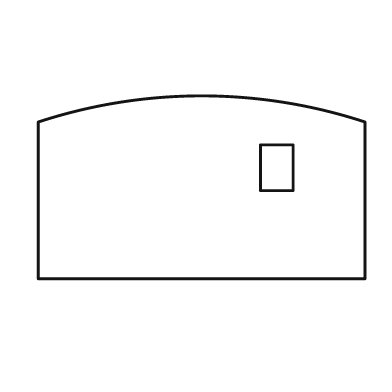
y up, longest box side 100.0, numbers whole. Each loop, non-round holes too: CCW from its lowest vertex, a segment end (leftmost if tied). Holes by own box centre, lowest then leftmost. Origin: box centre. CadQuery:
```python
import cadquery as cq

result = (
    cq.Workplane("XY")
    .moveTo(-50.0, -28.0)
    .lineTo(50.0, -28.0)
    .lineTo(50.0, 20.0)
    .threePointArc((0.0, 28.0), (-50.0, 20.0))
    .close()
    .moveTo(18.0, -1.0)
    .lineTo(28.0, -1.0)
    .lineTo(28.0, 13.0)
    .lineTo(18.0, 13.0)
    .close()
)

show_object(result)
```